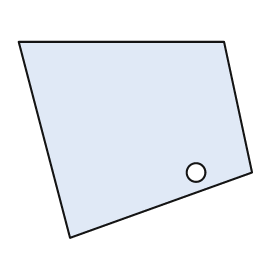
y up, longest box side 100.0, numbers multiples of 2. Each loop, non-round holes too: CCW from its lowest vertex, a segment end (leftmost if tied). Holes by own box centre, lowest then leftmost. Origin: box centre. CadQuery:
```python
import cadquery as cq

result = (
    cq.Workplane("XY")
    .moveTo(-28.0, -42.0)
    .lineTo(50.0, -14.0)
    .lineTo(38.0, 42.0)
    .lineTo(-50.0, 42.0)
    .close()
    .moveTo(26.0, -14.0)
    .circle(4.0)
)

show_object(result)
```